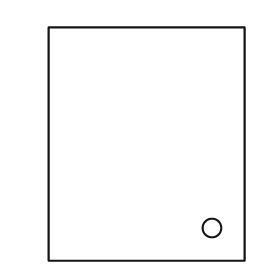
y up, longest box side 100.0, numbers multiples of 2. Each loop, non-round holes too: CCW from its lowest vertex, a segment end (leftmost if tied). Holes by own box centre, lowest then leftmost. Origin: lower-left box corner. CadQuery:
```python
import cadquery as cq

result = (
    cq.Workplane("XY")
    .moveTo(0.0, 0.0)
    .lineTo(84.0, 0.0)
    .lineTo(84.0, 100.0)
    .lineTo(0.0, 100.0)
    .close()
    .moveTo(70.0, 14.0)
    .circle(4.0)
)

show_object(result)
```